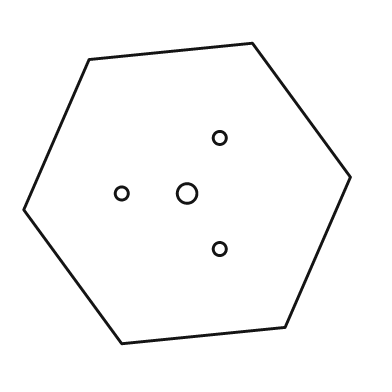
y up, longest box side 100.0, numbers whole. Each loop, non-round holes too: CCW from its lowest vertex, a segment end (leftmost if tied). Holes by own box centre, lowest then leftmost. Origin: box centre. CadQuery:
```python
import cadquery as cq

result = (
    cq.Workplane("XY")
    .moveTo(-20.0, -46.0)
    .lineTo(30.0, -41.0)
    .lineTo(50.0, 5.0)
    .lineTo(20.0, 46.0)
    .lineTo(-30.0, 41.0)
    .lineTo(-50.0, -5.0)
    .close()
    .moveTo(10.0, -17.0)
    .circle(2.0)
    .moveTo(-20.0, 0.0)
    .circle(2.0)
    .moveTo(0.0, 0.0)
    .circle(3.0)
    .moveTo(10.0, 17.0)
    .circle(2.0)
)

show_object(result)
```